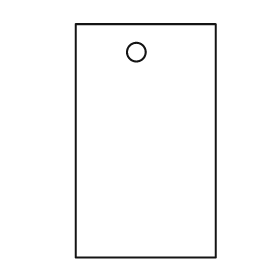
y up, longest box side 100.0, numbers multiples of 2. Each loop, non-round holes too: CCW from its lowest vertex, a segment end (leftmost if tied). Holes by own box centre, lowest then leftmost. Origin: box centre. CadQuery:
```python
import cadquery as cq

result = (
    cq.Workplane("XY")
    .moveTo(-30.0, -50.0)
    .lineTo(30.0, -50.0)
    .lineTo(30.0, 50.0)
    .lineTo(-30.0, 50.0)
    .close()
    .moveTo(-4.0, 38.0)
    .circle(4.0)
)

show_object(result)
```